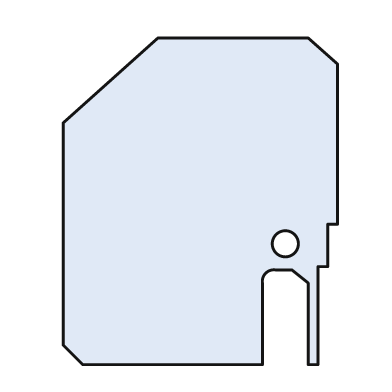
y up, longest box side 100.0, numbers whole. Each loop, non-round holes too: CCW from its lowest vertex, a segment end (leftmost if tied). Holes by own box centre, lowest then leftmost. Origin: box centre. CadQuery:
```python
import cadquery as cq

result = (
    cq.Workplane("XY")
    .moveTo(-36.0, -50.0)
    .lineTo(19.0, -50.0)
    .lineTo(19.0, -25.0)
    .threePointArc((20.0, -22.0), (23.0, -21.0))
    .lineTo(28.0, -21.0)
    .lineTo(33.0, -25.0)
    .lineTo(33.0, -50.0)
    .lineTo(36.0, -50.0)
    .lineTo(36.0, -20.0)
    .lineTo(39.0, -20.0)
    .lineTo(39.0, -7.0)
    .lineTo(42.0, -7.0)
    .lineTo(42.0, 42.0)
    .lineTo(33.0, 50.0)
    .lineTo(-13.0, 50.0)
    .lineTo(-42.0, 24.0)
    .lineTo(-42.0, -44.0)
    .close()
    .moveTo(26.0, -13.0)
    .circle(4.0)
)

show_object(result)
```